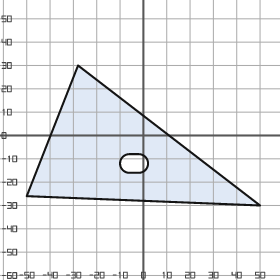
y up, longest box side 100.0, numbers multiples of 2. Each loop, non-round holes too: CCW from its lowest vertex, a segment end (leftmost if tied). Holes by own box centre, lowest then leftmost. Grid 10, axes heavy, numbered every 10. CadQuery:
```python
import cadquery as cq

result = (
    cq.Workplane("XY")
    .moveTo(50.0, -30.0)
    .lineTo(-28.0, 30.0)
    .lineTo(-50.0, -26.0)
    .close()
    .moveTo(-6.0, -16.0)
    .lineTo(-2.0, -16.0)
    .threePointArc((2.0, -12.0), (-2.0, -8.0))
    .lineTo(-6.0, -8.0)
    .threePointArc((-10.0, -12.0), (-6.0, -16.0))
    .close()
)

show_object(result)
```